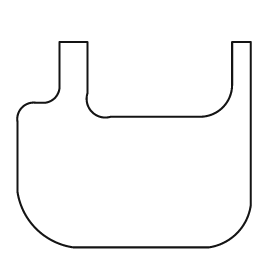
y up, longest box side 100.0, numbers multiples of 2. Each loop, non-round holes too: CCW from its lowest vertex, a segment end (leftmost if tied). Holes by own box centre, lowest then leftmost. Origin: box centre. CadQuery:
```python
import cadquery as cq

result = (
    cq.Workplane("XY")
    .moveTo(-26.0, -44.0)
    .lineTo(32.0, -44.0)
    .threePointArc((44.0, -38.0), (50.0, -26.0))
    .lineTo(50.0, 44.0)
    .lineTo(42.0, 44.0)
    .lineTo(42.0, 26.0)
    .threePointArc((38.0, 16.0), (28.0, 12.0))
    .lineTo(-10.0, 12.0)
    .threePointArc((-18.0, 14.0), (-20.0, 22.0))
    .lineTo(-20.0, 44.0)
    .lineTo(-32.0, 44.0)
    .lineTo(-32.0, 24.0)
    .threePointArc((-34.0, 20.0), (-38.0, 18.0))
    .lineTo(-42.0, 18.0)
    .threePointArc((-48.0, 16.0), (-50.0, 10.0))
    .lineTo(-50.0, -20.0)
    .threePointArc((-42.0, -36.0), (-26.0, -44.0))
    .close()
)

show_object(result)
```